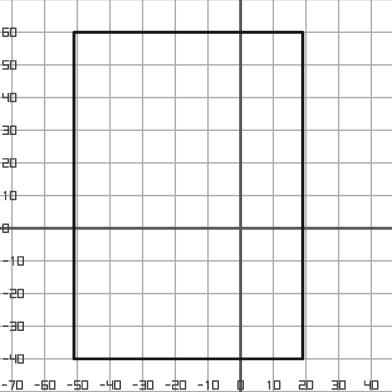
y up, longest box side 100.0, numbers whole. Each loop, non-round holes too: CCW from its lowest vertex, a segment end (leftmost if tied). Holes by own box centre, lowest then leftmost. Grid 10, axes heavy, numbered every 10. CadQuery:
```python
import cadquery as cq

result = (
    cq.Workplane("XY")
    .moveTo(-51.0, -40.0)
    .lineTo(19.0, -40.0)
    .lineTo(19.0, 60.0)
    .lineTo(-51.0, 60.0)
    .close()
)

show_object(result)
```